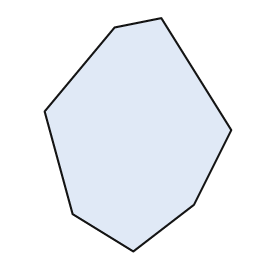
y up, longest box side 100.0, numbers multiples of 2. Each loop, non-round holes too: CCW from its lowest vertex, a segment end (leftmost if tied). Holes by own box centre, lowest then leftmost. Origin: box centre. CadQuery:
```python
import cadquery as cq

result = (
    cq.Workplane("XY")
    .moveTo(-2.0, -50.0)
    .lineTo(24.0, -30.0)
    .lineTo(40.0, 2.0)
    .lineTo(10.0, 50.0)
    .lineTo(-10.0, 46.0)
    .lineTo(-40.0, 10.0)
    .lineTo(-28.0, -34.0)
    .close()
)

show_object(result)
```